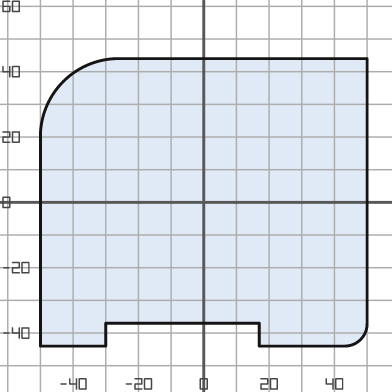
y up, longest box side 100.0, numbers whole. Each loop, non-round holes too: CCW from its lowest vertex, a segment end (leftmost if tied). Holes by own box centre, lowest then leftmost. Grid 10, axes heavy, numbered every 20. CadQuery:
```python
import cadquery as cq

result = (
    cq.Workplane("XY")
    .moveTo(-50.0, -44.0)
    .lineTo(-30.0, -44.0)
    .lineTo(-30.0, -37.0)
    .lineTo(17.0, -37.0)
    .lineTo(17.0, -44.0)
    .lineTo(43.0, -44.0)
    .threePointArc((48.0, -42.0), (50.0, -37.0))
    .lineTo(50.0, 44.0)
    .lineTo(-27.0, 44.0)
    .threePointArc((-43.0, 37.0), (-50.0, 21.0))
    .close()
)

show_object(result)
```